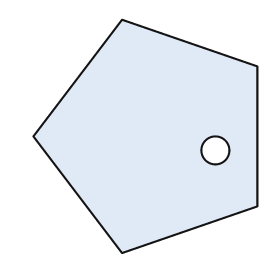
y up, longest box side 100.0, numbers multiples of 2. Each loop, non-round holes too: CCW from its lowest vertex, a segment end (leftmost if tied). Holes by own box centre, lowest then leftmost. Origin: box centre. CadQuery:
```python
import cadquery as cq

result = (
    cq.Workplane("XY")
    .moveTo(-10.0, -50.0)
    .lineTo(48.0, -30.0)
    .lineTo(48.0, 30.0)
    .lineTo(-10.0, 50.0)
    .lineTo(-48.0, 0.0)
    .close()
    .moveTo(30.0, -6.0)
    .circle(6.0)
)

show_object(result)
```